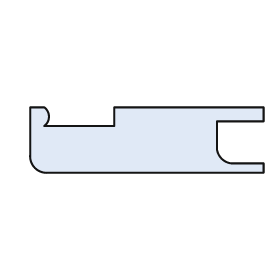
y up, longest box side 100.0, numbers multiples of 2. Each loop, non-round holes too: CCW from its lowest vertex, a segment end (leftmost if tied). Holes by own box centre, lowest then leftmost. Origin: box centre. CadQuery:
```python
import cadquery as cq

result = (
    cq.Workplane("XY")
    .moveTo(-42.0, -14.0)
    .lineTo(50.0, -14.0)
    .lineTo(50.0, -10.0)
    .lineTo(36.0, -10.0)
    .threePointArc((32.0, -8.0), (30.0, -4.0))
    .lineTo(30.0, 8.0)
    .lineTo(50.0, 8.0)
    .lineTo(50.0, 14.0)
    .lineTo(-14.0, 14.0)
    .lineTo(-14.0, 6.0)
    .lineTo(-44.0, 6.0)
    .threePointArc((-42.0, 10.0), (-44.0, 14.0))
    .lineTo(-50.0, 14.0)
    .lineTo(-50.0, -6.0)
    .threePointArc((-48.0, -12.0), (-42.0, -14.0))
    .close()
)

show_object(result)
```